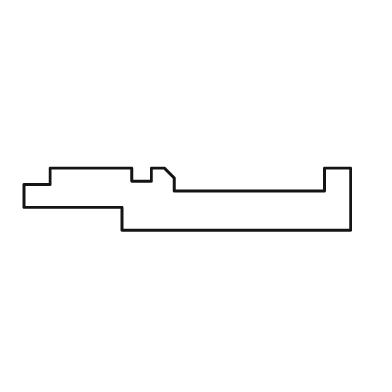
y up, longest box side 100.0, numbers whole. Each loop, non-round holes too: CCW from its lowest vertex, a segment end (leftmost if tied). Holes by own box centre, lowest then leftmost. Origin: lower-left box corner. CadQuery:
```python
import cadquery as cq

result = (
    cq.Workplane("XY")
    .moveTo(30.0, 0.0)
    .lineTo(100.0, 0.0)
    .lineTo(100.0, 19.0)
    .lineTo(92.0, 19.0)
    .lineTo(92.0, 12.0)
    .lineTo(46.0, 12.0)
    .lineTo(46.0, 16.0)
    .lineTo(43.0, 19.0)
    .lineTo(39.0, 19.0)
    .lineTo(39.0, 15.0)
    .lineTo(33.0, 15.0)
    .lineTo(33.0, 19.0)
    .lineTo(8.0, 19.0)
    .lineTo(8.0, 14.0)
    .lineTo(0.0, 14.0)
    .lineTo(0.0, 7.0)
    .lineTo(30.0, 7.0)
    .close()
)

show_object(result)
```